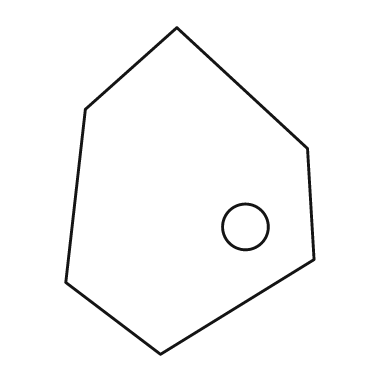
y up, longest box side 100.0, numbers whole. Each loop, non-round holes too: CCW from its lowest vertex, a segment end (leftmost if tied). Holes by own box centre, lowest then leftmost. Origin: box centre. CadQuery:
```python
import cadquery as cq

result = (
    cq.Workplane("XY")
    .moveTo(-9.0, -50.0)
    .lineTo(38.0, -21.0)
    .lineTo(36.0, 13.0)
    .lineTo(-4.0, 50.0)
    .lineTo(-32.0, 25.0)
    .lineTo(-38.0, -28.0)
    .close()
    .moveTo(17.0, -11.0)
    .circle(7.0)
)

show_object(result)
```